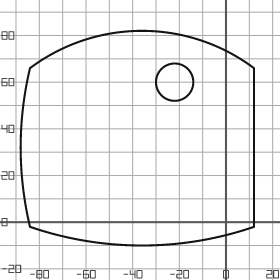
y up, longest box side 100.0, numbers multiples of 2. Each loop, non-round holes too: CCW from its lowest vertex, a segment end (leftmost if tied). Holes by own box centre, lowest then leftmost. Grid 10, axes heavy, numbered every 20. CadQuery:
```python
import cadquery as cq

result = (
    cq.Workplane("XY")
    .moveTo(-84.0, -2.0)
    .threePointArc((-36.0, -10.0), (12.0, -2.0))
    .lineTo(12.0, 66.0)
    .threePointArc((-36.0, 82.0), (-84.0, 66.0))
    .threePointArc((-88.0, 32.0), (-84.0, -2.0))
    .close()
    .moveTo(-22.0, 60.0)
    .circle(8.0)
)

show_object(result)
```